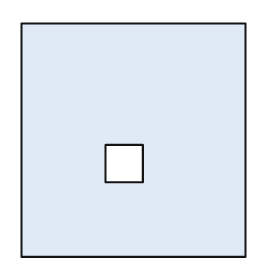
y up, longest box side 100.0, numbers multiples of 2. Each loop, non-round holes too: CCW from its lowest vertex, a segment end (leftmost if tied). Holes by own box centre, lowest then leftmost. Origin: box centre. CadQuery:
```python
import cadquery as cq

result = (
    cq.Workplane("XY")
    .moveTo(-48.0, -50.0)
    .lineTo(48.0, -50.0)
    .lineTo(48.0, 50.0)
    .lineTo(-48.0, 50.0)
    .close()
    .moveTo(-12.0, -18.0)
    .lineTo(4.0, -18.0)
    .lineTo(4.0, -2.0)
    .lineTo(-12.0, -2.0)
    .close()
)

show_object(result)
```